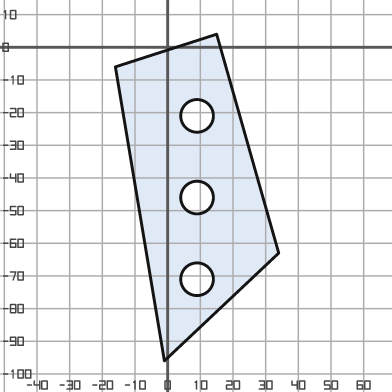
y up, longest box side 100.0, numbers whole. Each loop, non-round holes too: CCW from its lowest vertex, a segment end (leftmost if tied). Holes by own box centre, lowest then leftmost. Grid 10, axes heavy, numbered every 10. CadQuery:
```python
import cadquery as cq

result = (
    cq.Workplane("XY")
    .moveTo(-1.0, -96.0)
    .lineTo(34.0, -63.0)
    .lineTo(15.0, 4.0)
    .lineTo(-16.0, -6.0)
    .close()
    .moveTo(9.0, -71.0)
    .circle(5.0)
    .moveTo(9.0, -46.0)
    .circle(5.0)
    .moveTo(9.0, -21.0)
    .circle(5.0)
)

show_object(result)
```